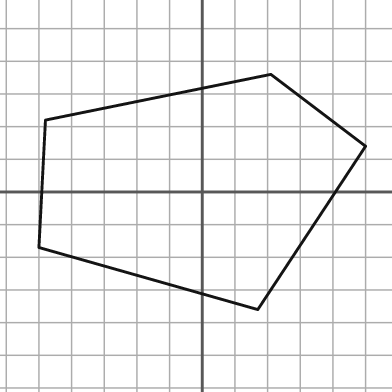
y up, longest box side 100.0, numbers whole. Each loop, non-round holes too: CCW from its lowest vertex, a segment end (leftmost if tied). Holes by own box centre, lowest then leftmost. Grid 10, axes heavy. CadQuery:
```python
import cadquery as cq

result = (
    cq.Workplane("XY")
    .moveTo(17.0, -36.0)
    .lineTo(50.0, 14.0)
    .lineTo(21.0, 36.0)
    .lineTo(-48.0, 22.0)
    .lineTo(-50.0, -17.0)
    .close()
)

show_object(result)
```